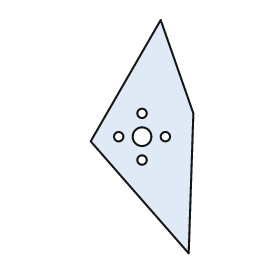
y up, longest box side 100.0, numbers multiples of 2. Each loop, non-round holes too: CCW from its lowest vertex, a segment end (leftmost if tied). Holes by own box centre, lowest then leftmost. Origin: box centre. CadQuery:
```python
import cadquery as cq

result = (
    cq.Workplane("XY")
    .moveTo(20.0, -50.0)
    .lineTo(22.0, 10.0)
    .lineTo(8.0, 50.0)
    .lineTo(-22.0, -2.0)
    .close()
    .moveTo(0.0, -10.0)
    .circle(2.0)
    .moveTo(-10.0, 0.0)
    .circle(2.0)
    .moveTo(0.0, 0.0)
    .circle(4.0)
    .moveTo(10.0, 0.0)
    .circle(2.0)
    .moveTo(0.0, 10.0)
    .circle(2.0)
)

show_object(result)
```